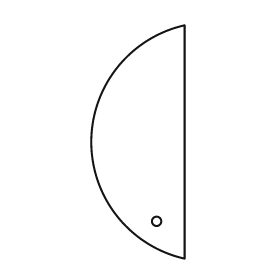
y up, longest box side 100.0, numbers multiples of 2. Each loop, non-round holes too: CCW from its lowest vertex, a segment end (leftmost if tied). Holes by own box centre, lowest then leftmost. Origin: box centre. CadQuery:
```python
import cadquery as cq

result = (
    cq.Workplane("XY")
    .moveTo(20.0, -50.0)
    .lineTo(20.0, 50.0)
    .threePointArc((-20.0, 0.0), (20.0, -50.0))
    .close()
    .moveTo(8.0, -34.0)
    .circle(2.0)
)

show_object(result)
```